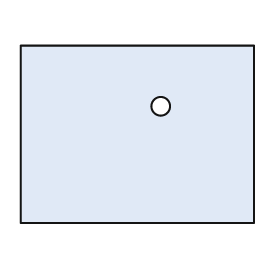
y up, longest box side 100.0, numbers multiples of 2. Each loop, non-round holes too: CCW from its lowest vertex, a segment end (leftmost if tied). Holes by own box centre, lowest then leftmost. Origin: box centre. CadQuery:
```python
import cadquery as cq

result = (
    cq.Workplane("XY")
    .moveTo(-50.0, -38.0)
    .lineTo(50.0, -38.0)
    .lineTo(50.0, 38.0)
    .lineTo(-50.0, 38.0)
    .close()
    .moveTo(10.0, 12.0)
    .circle(4.0)
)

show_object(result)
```